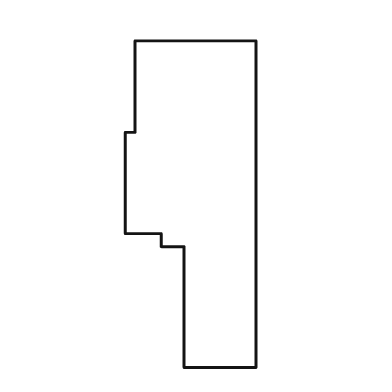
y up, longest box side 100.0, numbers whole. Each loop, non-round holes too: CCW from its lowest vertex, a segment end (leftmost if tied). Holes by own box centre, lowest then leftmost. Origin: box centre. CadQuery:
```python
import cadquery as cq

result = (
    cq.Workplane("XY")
    .moveTo(-2.0, -50.0)
    .lineTo(20.0, -50.0)
    .lineTo(20.0, 50.0)
    .lineTo(-17.0, 50.0)
    .lineTo(-17.0, 22.0)
    .lineTo(-20.0, 22.0)
    .lineTo(-20.0, -9.0)
    .lineTo(-9.0, -9.0)
    .lineTo(-9.0, -13.0)
    .lineTo(-2.0, -13.0)
    .close()
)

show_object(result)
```